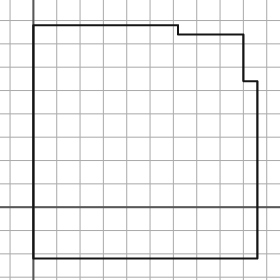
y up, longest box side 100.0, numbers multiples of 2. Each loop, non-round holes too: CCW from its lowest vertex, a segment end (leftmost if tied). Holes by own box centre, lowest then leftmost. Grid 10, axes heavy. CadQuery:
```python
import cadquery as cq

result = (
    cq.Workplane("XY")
    .moveTo(0.0, -22.0)
    .lineTo(96.0, -22.0)
    .lineTo(96.0, 54.0)
    .lineTo(90.0, 54.0)
    .lineTo(90.0, 74.0)
    .lineTo(62.0, 74.0)
    .lineTo(62.0, 78.0)
    .lineTo(0.0, 78.0)
    .close()
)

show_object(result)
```